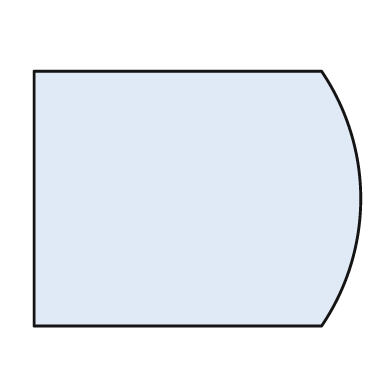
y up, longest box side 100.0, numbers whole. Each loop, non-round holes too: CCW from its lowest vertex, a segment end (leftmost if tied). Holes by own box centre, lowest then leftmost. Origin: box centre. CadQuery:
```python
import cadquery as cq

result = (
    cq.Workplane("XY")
    .moveTo(-50.0, -39.0)
    .lineTo(38.0, -39.0)
    .threePointArc((50.0, 0.0), (38.0, 39.0))
    .lineTo(-50.0, 39.0)
    .close()
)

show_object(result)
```